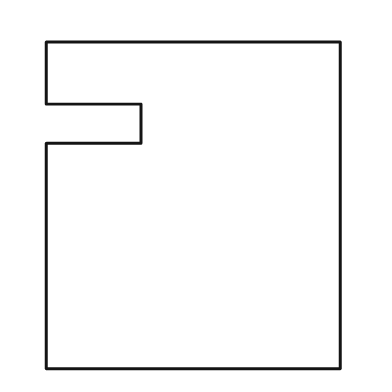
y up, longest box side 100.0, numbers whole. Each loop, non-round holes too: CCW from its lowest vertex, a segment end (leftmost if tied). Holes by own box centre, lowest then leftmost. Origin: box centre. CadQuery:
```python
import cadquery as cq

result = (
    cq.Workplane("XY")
    .moveTo(-45.0, -50.0)
    .lineTo(45.0, -50.0)
    .lineTo(45.0, 50.0)
    .lineTo(-45.0, 50.0)
    .lineTo(-45.0, 31.0)
    .lineTo(-16.0, 31.0)
    .lineTo(-16.0, 19.0)
    .lineTo(-45.0, 19.0)
    .close()
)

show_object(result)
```